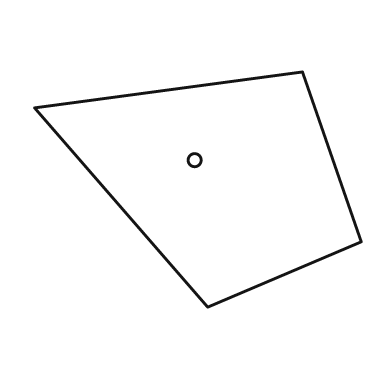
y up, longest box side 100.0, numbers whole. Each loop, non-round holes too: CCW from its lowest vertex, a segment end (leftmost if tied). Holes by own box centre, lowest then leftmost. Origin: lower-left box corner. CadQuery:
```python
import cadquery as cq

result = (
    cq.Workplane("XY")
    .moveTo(53.0, 0.0)
    .lineTo(100.0, 20.0)
    .lineTo(82.0, 72.0)
    .lineTo(0.0, 61.0)
    .close()
    .moveTo(49.0, 45.0)
    .circle(2.0)
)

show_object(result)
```